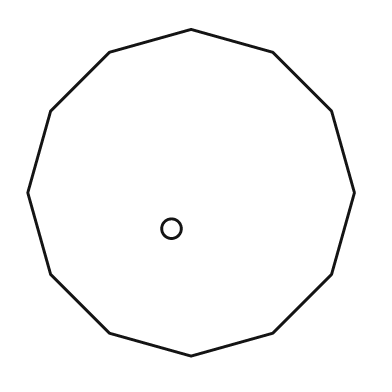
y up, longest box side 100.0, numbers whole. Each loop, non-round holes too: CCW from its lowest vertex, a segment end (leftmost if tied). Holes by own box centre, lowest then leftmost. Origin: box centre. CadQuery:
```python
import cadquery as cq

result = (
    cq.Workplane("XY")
    .moveTo(0.0, -50.0)
    .lineTo(25.0, -43.0)
    .lineTo(43.0, -25.0)
    .lineTo(50.0, 0.0)
    .lineTo(43.0, 25.0)
    .lineTo(25.0, 43.0)
    .lineTo(0.0, 50.0)
    .lineTo(-25.0, 43.0)
    .lineTo(-43.0, 25.0)
    .lineTo(-50.0, 0.0)
    .lineTo(-43.0, -25.0)
    .lineTo(-25.0, -43.0)
    .close()
    .moveTo(-6.0, -11.0)
    .circle(3.0)
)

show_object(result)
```